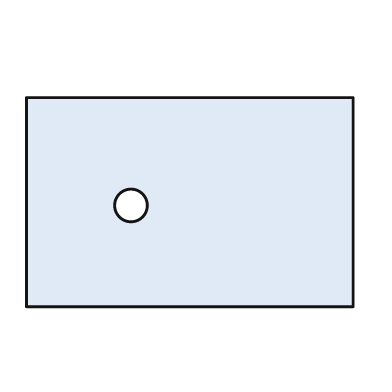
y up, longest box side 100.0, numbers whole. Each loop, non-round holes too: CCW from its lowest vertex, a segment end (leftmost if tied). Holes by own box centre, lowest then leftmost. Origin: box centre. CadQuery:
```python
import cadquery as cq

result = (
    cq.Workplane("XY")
    .moveTo(-50.0, -32.0)
    .lineTo(50.0, -32.0)
    .lineTo(50.0, 32.0)
    .lineTo(-50.0, 32.0)
    .close()
    .moveTo(-18.0, -1.0)
    .circle(5.0)
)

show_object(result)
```